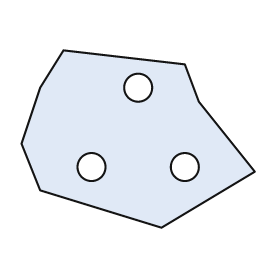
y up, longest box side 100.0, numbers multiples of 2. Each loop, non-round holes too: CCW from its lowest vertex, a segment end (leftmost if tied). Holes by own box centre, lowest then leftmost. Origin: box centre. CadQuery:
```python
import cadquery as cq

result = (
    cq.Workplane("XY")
    .moveTo(10.0, -38.0)
    .lineTo(50.0, -14.0)
    .lineTo(26.0, 16.0)
    .lineTo(20.0, 32.0)
    .lineTo(-32.0, 38.0)
    .lineTo(-42.0, 22.0)
    .lineTo(-50.0, -2.0)
    .lineTo(-42.0, -22.0)
    .close()
    .moveTo(-20.0, -12.0)
    .circle(6.0)
    .moveTo(20.0, -12.0)
    .circle(6.0)
    .moveTo(0.0, 22.0)
    .circle(6.0)
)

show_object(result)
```